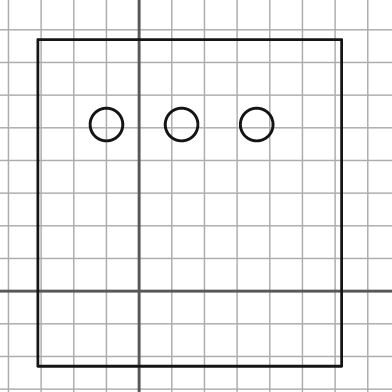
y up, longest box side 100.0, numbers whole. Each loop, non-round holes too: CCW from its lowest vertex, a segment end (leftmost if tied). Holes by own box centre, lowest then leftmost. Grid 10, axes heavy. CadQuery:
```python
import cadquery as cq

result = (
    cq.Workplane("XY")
    .moveTo(-31.0, -23.0)
    .lineTo(62.0, -23.0)
    .lineTo(62.0, 77.0)
    .lineTo(-31.0, 77.0)
    .close()
    .moveTo(-10.0, 51.0)
    .circle(5.0)
    .moveTo(13.0, 51.0)
    .circle(5.0)
    .moveTo(36.0, 51.0)
    .circle(5.0)
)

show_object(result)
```